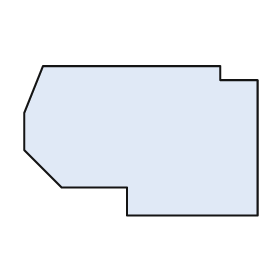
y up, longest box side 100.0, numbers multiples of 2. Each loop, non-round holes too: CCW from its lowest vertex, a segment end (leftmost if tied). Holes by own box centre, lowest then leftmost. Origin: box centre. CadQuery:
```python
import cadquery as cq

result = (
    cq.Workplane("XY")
    .moveTo(-6.0, -32.0)
    .lineTo(50.0, -32.0)
    .lineTo(50.0, 26.0)
    .lineTo(34.0, 26.0)
    .lineTo(34.0, 32.0)
    .lineTo(-42.0, 32.0)
    .lineTo(-50.0, 12.0)
    .lineTo(-50.0, -4.0)
    .lineTo(-34.0, -20.0)
    .lineTo(-6.0, -20.0)
    .close()
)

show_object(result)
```